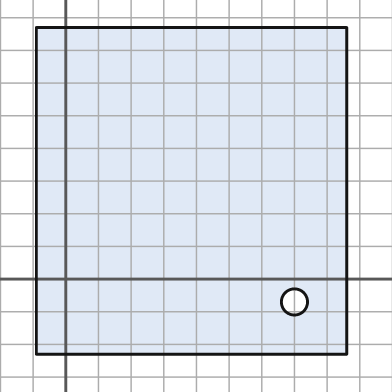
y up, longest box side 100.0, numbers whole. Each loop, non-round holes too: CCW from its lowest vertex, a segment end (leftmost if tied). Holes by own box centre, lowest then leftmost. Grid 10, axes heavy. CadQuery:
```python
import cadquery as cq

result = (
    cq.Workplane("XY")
    .moveTo(-9.0, -23.0)
    .lineTo(86.0, -23.0)
    .lineTo(86.0, 77.0)
    .lineTo(-9.0, 77.0)
    .close()
    .moveTo(70.0, -7.0)
    .circle(4.0)
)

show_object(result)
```